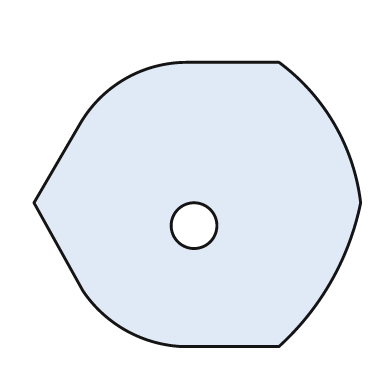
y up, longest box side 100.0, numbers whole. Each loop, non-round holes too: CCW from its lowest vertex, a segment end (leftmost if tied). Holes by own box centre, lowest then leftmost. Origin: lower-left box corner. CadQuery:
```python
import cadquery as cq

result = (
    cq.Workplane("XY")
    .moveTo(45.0, 0.0)
    .lineTo(75.0, 0.0)
    .threePointArc((91.0, 20.0), (100.0, 44.0))
    .threePointArc((92.0, 68.0), (75.0, 87.0))
    .lineTo(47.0, 87.0)
    .threePointArc((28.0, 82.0), (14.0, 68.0))
    .lineTo(0.0, 44.0)
    .lineTo(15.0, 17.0)
    .threePointArc((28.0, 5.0), (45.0, 0.0))
    .close()
    .moveTo(49.0, 37.0)
    .circle(7.0)
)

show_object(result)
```